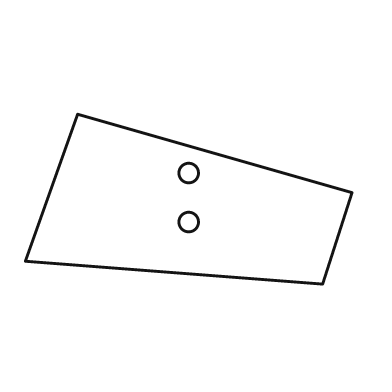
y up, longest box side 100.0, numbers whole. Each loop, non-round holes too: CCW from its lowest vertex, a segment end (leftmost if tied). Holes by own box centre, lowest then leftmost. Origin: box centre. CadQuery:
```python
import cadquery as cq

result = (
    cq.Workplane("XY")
    .moveTo(41.0, -26.0)
    .lineTo(50.0, 2.0)
    .lineTo(-34.0, 26.0)
    .lineTo(-50.0, -19.0)
    .close()
    .moveTo(0.0, -7.0)
    .circle(3.0)
    .moveTo(0.0, 8.0)
    .circle(3.0)
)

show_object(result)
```